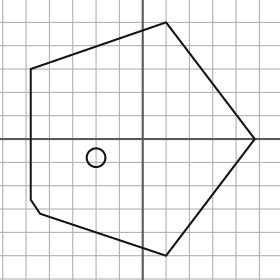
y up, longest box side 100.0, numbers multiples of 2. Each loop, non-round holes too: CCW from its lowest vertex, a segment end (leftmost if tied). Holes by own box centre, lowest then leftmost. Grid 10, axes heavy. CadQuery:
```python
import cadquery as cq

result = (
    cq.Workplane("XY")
    .moveTo(10.0, -50.0)
    .lineTo(48.0, 0.0)
    .lineTo(10.0, 50.0)
    .lineTo(-48.0, 30.0)
    .lineTo(-48.0, -26.0)
    .lineTo(-44.0, -32.0)
    .close()
    .moveTo(-20.0, -8.0)
    .circle(4.0)
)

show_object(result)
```